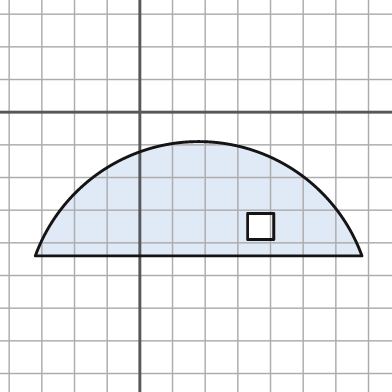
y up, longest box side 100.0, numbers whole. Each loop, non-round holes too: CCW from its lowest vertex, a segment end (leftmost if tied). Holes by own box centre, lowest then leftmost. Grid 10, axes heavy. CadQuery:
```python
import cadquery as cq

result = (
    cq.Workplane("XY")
    .moveTo(-32.0, -44.0)
    .lineTo(68.0, -44.0)
    .threePointArc((18.0, -9.0), (-32.0, -44.0))
    .close()
    .moveTo(33.0, -39.0)
    .lineTo(41.0, -39.0)
    .lineTo(41.0, -31.0)
    .lineTo(33.0, -31.0)
    .close()
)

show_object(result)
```